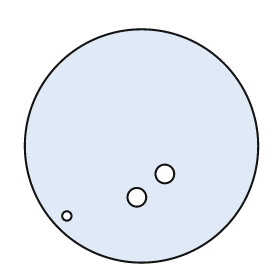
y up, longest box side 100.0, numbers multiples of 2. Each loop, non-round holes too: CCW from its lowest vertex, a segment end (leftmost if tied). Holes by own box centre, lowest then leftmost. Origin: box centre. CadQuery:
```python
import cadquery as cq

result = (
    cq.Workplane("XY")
    .moveTo(0.0, 0.0)
    .circle(50.0)
    .moveTo(-32.0, -30.0)
    .circle(2.0)
    .moveTo(-2.0, -22.0)
    .circle(4.0)
    .moveTo(10.0, -12.0)
    .circle(4.0)
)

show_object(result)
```